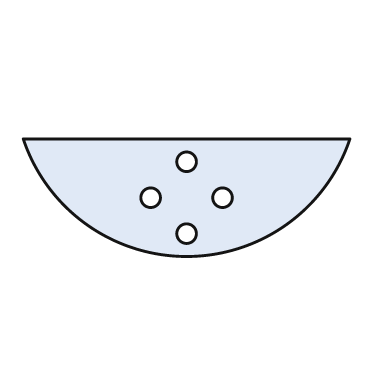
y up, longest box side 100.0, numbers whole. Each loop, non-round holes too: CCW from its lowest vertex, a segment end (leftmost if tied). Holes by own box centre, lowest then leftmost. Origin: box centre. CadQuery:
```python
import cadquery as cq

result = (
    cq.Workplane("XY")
    .moveTo(-50.0, 18.0)
    .threePointArc((0.0, -18.0), (50.0, 18.0))
    .close()
    .moveTo(0.0, -11.0)
    .circle(3.0)
    .moveTo(-11.0, 0.0)
    .circle(3.0)
    .moveTo(11.0, 0.0)
    .circle(3.0)
    .moveTo(0.0, 11.0)
    .circle(3.0)
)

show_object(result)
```